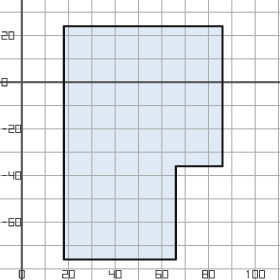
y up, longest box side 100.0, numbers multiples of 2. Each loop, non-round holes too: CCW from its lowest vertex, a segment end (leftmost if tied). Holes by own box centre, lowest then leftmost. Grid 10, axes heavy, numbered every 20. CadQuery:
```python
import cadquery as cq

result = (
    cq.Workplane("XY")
    .moveTo(18.0, -76.0)
    .lineTo(66.0, -76.0)
    .lineTo(66.0, -36.0)
    .lineTo(86.0, -36.0)
    .lineTo(86.0, 24.0)
    .lineTo(18.0, 24.0)
    .close()
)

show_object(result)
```